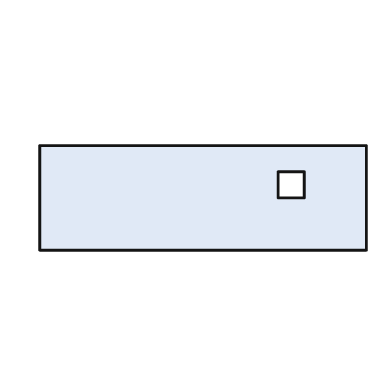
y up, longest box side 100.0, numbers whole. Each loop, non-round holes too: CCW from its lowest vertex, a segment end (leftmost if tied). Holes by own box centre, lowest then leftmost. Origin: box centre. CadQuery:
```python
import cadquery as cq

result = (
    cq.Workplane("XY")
    .moveTo(-50.0, -16.0)
    .lineTo(50.0, -16.0)
    .lineTo(50.0, 16.0)
    .lineTo(-50.0, 16.0)
    .close()
    .moveTo(23.0, 0.0)
    .lineTo(31.0, 0.0)
    .lineTo(31.0, 8.0)
    .lineTo(23.0, 8.0)
    .close()
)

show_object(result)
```